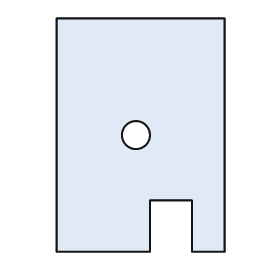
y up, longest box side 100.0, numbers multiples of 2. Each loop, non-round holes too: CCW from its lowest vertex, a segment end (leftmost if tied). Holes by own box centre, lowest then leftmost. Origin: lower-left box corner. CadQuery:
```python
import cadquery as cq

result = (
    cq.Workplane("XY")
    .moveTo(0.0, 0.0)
    .lineTo(40.0, 0.0)
    .lineTo(40.0, 22.0)
    .lineTo(58.0, 22.0)
    .lineTo(58.0, 0.0)
    .lineTo(72.0, 0.0)
    .lineTo(72.0, 100.0)
    .lineTo(0.0, 100.0)
    .close()
    .moveTo(34.0, 50.0)
    .circle(6.0)
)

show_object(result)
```